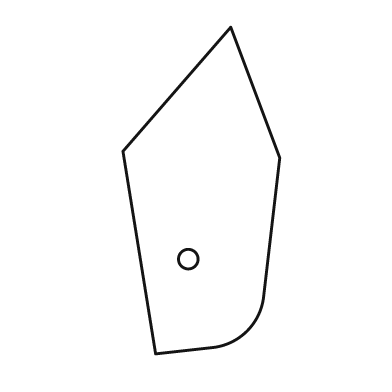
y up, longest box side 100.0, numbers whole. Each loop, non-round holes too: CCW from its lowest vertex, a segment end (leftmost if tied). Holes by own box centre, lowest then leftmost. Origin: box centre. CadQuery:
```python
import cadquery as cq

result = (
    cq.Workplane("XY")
    .moveTo(-14.0, -50.0)
    .lineTo(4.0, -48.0)
    .threePointArc((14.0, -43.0), (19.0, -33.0))
    .lineTo(24.0, 10.0)
    .lineTo(9.0, 50.0)
    .lineTo(-24.0, 12.0)
    .close()
    .moveTo(-4.0, -21.0)
    .circle(3.0)
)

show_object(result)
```